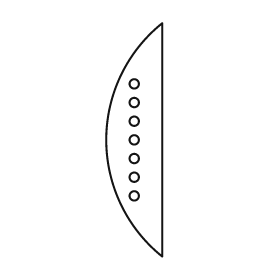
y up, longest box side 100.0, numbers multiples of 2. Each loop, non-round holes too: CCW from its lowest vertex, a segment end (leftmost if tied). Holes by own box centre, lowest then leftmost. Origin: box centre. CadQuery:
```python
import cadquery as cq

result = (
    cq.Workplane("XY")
    .moveTo(12.0, -50.0)
    .lineTo(12.0, 50.0)
    .threePointArc((-12.0, 0.0), (12.0, -50.0))
    .close()
    .moveTo(0.0, -24.0)
    .circle(2.0)
    .moveTo(0.0, -16.0)
    .circle(2.0)
    .moveTo(0.0, -8.0)
    .circle(2.0)
    .moveTo(0.0, 0.0)
    .circle(2.0)
    .moveTo(0.0, 8.0)
    .circle(2.0)
    .moveTo(0.0, 16.0)
    .circle(2.0)
    .moveTo(0.0, 24.0)
    .circle(2.0)
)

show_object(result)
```